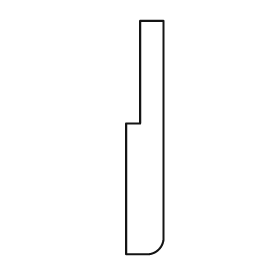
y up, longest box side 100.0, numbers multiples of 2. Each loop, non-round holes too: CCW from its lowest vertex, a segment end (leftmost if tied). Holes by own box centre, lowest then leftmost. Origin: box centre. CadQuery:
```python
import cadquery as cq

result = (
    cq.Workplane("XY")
    .moveTo(-8.0, -50.0)
    .lineTo(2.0, -50.0)
    .threePointArc((6.0, -48.0), (8.0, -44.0))
    .lineTo(8.0, 50.0)
    .lineTo(-2.0, 50.0)
    .lineTo(-2.0, 6.0)
    .lineTo(-8.0, 6.0)
    .close()
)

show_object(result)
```